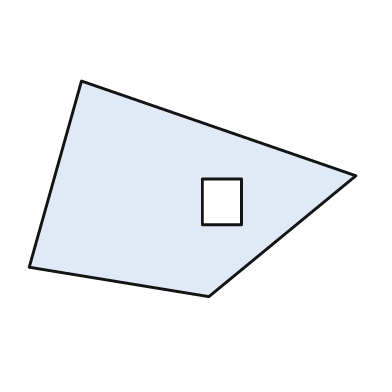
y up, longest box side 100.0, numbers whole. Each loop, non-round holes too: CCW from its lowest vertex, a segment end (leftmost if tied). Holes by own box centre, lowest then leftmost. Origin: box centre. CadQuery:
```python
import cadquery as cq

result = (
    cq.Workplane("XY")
    .moveTo(5.0, -33.0)
    .lineTo(50.0, 4.0)
    .lineTo(-34.0, 33.0)
    .lineTo(-50.0, -24.0)
    .close()
    .moveTo(3.0, -11.0)
    .lineTo(15.0, -11.0)
    .lineTo(15.0, 3.0)
    .lineTo(3.0, 3.0)
    .close()
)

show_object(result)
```